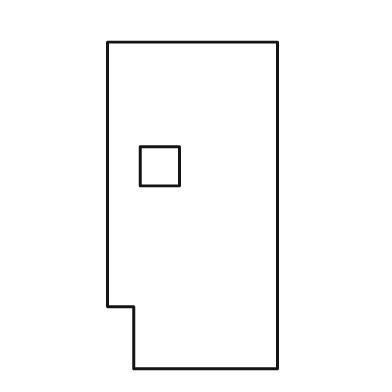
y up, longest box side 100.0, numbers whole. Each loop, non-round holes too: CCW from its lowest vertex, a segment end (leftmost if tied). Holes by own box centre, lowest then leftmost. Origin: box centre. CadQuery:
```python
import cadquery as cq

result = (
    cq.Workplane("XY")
    .moveTo(-18.0, -50.0)
    .lineTo(26.0, -50.0)
    .lineTo(26.0, 50.0)
    .lineTo(-26.0, 50.0)
    .lineTo(-26.0, -31.0)
    .lineTo(-18.0, -31.0)
    .close()
    .moveTo(-16.0, 6.0)
    .lineTo(-4.0, 6.0)
    .lineTo(-4.0, 18.0)
    .lineTo(-16.0, 18.0)
    .close()
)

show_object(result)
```